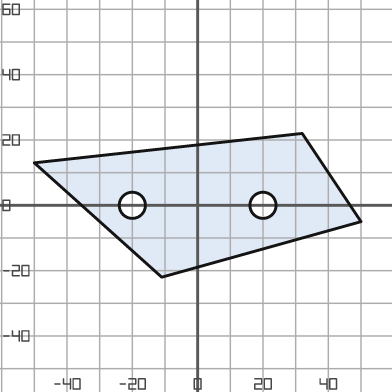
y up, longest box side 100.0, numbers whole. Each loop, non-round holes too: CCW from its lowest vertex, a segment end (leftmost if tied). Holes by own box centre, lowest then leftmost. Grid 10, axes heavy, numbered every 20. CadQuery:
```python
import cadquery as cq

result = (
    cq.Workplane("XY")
    .moveTo(-11.0, -22.0)
    .lineTo(50.0, -5.0)
    .lineTo(32.0, 22.0)
    .lineTo(-50.0, 13.0)
    .close()
    .moveTo(-20.0, 0.0)
    .circle(4.0)
    .moveTo(20.0, 0.0)
    .circle(4.0)
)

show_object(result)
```